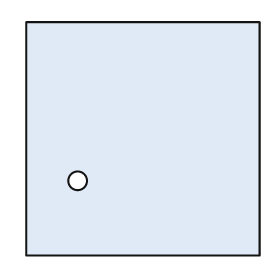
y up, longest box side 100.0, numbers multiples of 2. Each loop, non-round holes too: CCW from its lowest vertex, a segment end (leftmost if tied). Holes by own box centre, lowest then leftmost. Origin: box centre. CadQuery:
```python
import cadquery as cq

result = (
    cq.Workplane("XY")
    .moveTo(-50.0, -50.0)
    .lineTo(50.0, -50.0)
    .lineTo(50.0, 50.0)
    .lineTo(-50.0, 50.0)
    .close()
    .moveTo(-28.0, -18.0)
    .circle(4.0)
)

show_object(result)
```